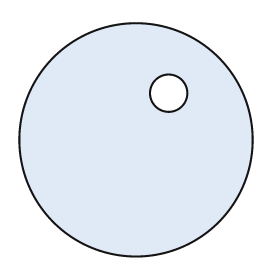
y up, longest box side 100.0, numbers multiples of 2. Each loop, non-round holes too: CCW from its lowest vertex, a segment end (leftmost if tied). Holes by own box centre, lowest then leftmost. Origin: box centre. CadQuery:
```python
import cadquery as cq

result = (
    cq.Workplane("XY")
    .moveTo(0.0, 0.0)
    .circle(50.0)
    .moveTo(14.0, 20.0)
    .circle(8.0)
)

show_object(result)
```